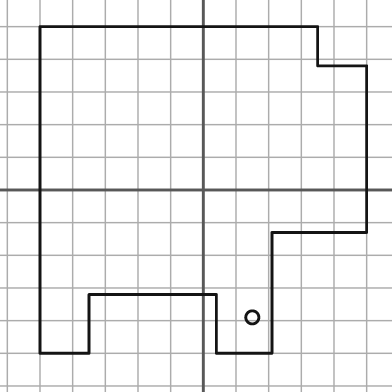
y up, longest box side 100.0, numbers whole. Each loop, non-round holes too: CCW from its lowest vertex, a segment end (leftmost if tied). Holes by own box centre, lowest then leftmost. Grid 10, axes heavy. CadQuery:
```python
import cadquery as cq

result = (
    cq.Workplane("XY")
    .moveTo(-50.0, -50.0)
    .lineTo(-35.0, -50.0)
    .lineTo(-35.0, -32.0)
    .lineTo(4.0, -32.0)
    .lineTo(4.0, -50.0)
    .lineTo(21.0, -50.0)
    .lineTo(21.0, -13.0)
    .lineTo(50.0, -13.0)
    .lineTo(50.0, 38.0)
    .lineTo(35.0, 38.0)
    .lineTo(35.0, 50.0)
    .lineTo(-50.0, 50.0)
    .close()
    .moveTo(15.0, -39.0)
    .circle(2.0)
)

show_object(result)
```